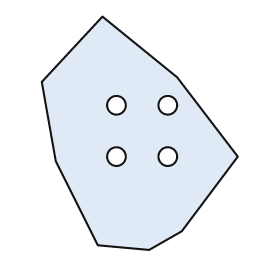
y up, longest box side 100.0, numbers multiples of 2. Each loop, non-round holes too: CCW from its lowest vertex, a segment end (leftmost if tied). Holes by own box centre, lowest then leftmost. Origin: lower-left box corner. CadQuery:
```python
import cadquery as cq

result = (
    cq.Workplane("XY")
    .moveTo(46.0, 0.0)
    .lineTo(60.0, 8.0)
    .lineTo(84.0, 40.0)
    .lineTo(58.0, 74.0)
    .lineTo(26.0, 100.0)
    .lineTo(0.0, 72.0)
    .lineTo(6.0, 38.0)
    .lineTo(24.0, 2.0)
    .close()
    .moveTo(32.0, 40.0)
    .circle(4.0)
    .moveTo(54.0, 40.0)
    .circle(4.0)
    .moveTo(32.0, 62.0)
    .circle(4.0)
    .moveTo(54.0, 62.0)
    .circle(4.0)
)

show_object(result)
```